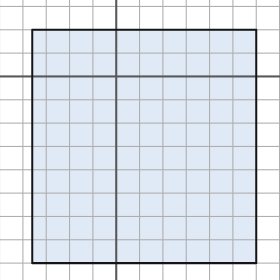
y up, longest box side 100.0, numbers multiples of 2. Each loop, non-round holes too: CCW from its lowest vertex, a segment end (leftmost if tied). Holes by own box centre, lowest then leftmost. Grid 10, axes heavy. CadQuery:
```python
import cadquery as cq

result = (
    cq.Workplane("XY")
    .moveTo(-36.0, -80.0)
    .lineTo(60.0, -80.0)
    .lineTo(60.0, 20.0)
    .lineTo(-36.0, 20.0)
    .close()
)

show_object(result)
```